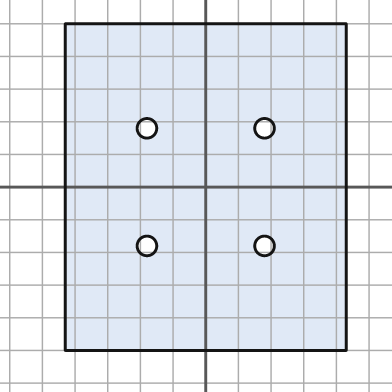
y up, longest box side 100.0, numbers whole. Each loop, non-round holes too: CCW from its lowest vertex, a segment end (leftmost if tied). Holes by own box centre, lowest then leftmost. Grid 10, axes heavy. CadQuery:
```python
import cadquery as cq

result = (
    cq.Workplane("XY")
    .moveTo(-43.0, -50.0)
    .lineTo(43.0, -50.0)
    .lineTo(43.0, 50.0)
    .lineTo(-43.0, 50.0)
    .close()
    .moveTo(-18.0, -18.0)
    .circle(3.0)
    .moveTo(18.0, -18.0)
    .circle(3.0)
    .moveTo(-18.0, 18.0)
    .circle(3.0)
    .moveTo(18.0, 18.0)
    .circle(3.0)
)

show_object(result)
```